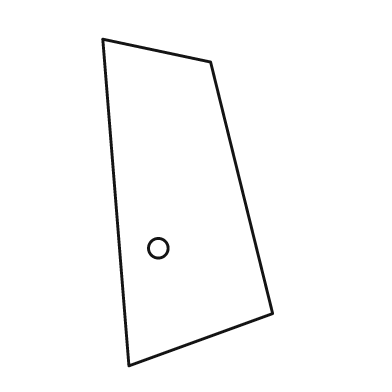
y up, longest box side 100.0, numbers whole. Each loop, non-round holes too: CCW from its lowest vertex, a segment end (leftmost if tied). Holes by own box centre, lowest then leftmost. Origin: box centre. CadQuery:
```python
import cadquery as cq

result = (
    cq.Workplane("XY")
    .moveTo(-18.0, -50.0)
    .lineTo(26.0, -34.0)
    .lineTo(7.0, 43.0)
    .lineTo(-26.0, 50.0)
    .close()
    .moveTo(-9.0, -14.0)
    .circle(3.0)
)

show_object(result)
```